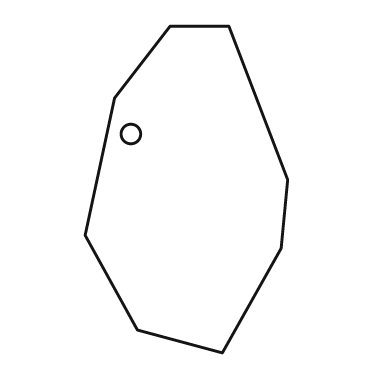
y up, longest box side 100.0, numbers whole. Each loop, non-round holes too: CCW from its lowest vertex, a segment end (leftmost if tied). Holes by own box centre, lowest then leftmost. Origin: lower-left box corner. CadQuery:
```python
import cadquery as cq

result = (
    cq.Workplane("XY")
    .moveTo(42.0, 0.0)
    .lineTo(60.0, 32.0)
    .lineTo(62.0, 53.0)
    .lineTo(44.0, 100.0)
    .lineTo(26.0, 100.0)
    .lineTo(9.0, 78.0)
    .lineTo(0.0, 36.0)
    .lineTo(16.0, 7.0)
    .close()
    .moveTo(14.0, 67.0)
    .circle(3.0)
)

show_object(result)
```